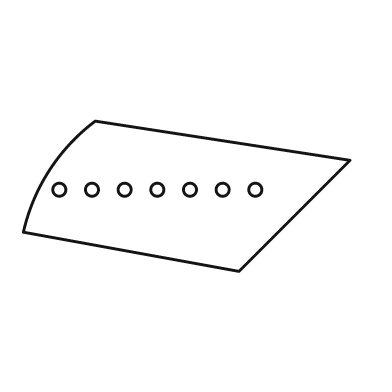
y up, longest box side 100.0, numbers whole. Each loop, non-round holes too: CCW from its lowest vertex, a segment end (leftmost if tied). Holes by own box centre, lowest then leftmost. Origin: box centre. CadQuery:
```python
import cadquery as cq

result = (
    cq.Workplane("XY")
    .moveTo(16.0, -23.0)
    .lineTo(50.0, 11.0)
    .lineTo(-28.0, 23.0)
    .threePointArc((-42.0, 8.0), (-50.0, -11.0))
    .close()
    .moveTo(-39.0, 2.0)
    .circle(2.0)
    .moveTo(-29.0, 2.0)
    .circle(2.0)
    .moveTo(-19.0, 2.0)
    .circle(2.0)
    .moveTo(-9.0, 2.0)
    .circle(2.0)
    .moveTo(1.0, 2.0)
    .circle(2.0)
    .moveTo(11.0, 2.0)
    .circle(2.0)
    .moveTo(21.0, 2.0)
    .circle(2.0)
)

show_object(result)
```